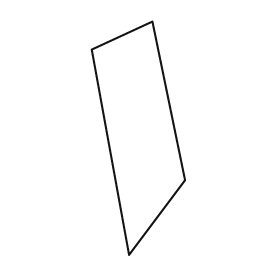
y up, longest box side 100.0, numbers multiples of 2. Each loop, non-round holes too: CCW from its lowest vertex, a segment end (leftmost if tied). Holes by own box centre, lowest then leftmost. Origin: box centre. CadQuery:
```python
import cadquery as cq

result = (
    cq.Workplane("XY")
    .moveTo(-4.0, -50.0)
    .lineTo(20.0, -18.0)
    .lineTo(6.0, 50.0)
    .lineTo(-20.0, 38.0)
    .close()
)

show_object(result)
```